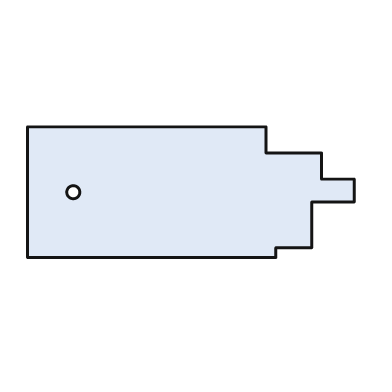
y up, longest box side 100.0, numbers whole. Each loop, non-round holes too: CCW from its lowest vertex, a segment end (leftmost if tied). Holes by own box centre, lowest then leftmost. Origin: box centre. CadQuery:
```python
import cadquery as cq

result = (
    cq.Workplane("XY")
    .moveTo(-50.0, -20.0)
    .lineTo(26.0, -20.0)
    .lineTo(26.0, -17.0)
    .lineTo(37.0, -17.0)
    .lineTo(37.0, -3.0)
    .lineTo(50.0, -3.0)
    .lineTo(50.0, 4.0)
    .lineTo(40.0, 4.0)
    .lineTo(40.0, 12.0)
    .lineTo(23.0, 12.0)
    .lineTo(23.0, 20.0)
    .lineTo(-50.0, 20.0)
    .close()
    .moveTo(-36.0, 0.0)
    .circle(2.0)
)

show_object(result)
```